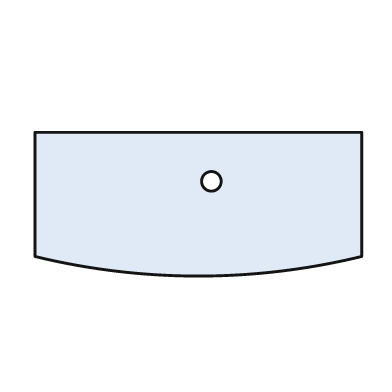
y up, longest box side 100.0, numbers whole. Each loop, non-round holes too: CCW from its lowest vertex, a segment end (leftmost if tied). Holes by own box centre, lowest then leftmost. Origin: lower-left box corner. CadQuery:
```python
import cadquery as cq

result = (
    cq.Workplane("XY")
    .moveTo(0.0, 6.0)
    .threePointArc((50.0, 0.0), (100.0, 6.0))
    .lineTo(100.0, 44.0)
    .lineTo(0.0, 44.0)
    .close()
    .moveTo(54.0, 29.0)
    .circle(3.0)
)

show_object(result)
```